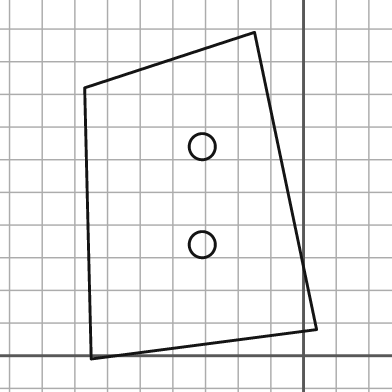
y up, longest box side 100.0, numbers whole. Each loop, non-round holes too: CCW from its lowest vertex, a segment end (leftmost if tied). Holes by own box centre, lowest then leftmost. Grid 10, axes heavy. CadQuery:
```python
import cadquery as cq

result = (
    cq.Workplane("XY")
    .moveTo(-65.0, -1.0)
    .lineTo(4.0, 8.0)
    .lineTo(-15.0, 99.0)
    .lineTo(-67.0, 82.0)
    .close()
    .moveTo(-31.0, 34.0)
    .circle(4.0)
    .moveTo(-31.0, 64.0)
    .circle(4.0)
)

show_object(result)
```